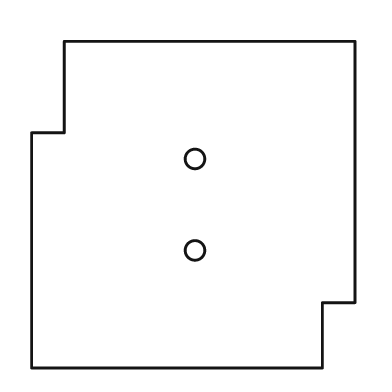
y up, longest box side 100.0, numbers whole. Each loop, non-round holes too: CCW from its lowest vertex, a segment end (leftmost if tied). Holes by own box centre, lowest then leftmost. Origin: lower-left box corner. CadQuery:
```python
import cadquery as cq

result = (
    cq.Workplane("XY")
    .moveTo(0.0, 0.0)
    .lineTo(89.0, 0.0)
    .lineTo(89.0, 20.0)
    .lineTo(99.0, 20.0)
    .lineTo(99.0, 100.0)
    .lineTo(10.0, 100.0)
    .lineTo(10.0, 72.0)
    .lineTo(0.0, 72.0)
    .close()
    .moveTo(50.0, 36.0)
    .circle(3.0)
    .moveTo(50.0, 64.0)
    .circle(3.0)
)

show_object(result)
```